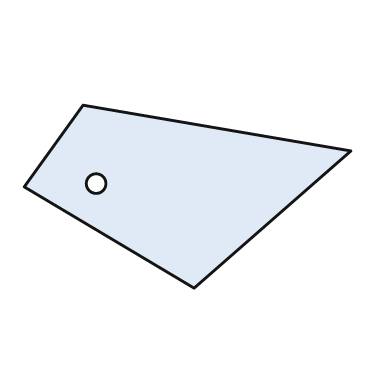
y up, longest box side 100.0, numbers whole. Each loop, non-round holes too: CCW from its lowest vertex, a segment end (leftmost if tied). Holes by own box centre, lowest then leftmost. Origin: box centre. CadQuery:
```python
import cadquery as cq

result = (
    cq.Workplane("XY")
    .moveTo(2.0, -28.0)
    .lineTo(50.0, 14.0)
    .lineTo(-32.0, 28.0)
    .lineTo(-50.0, 3.0)
    .close()
    .moveTo(-28.0, 4.0)
    .circle(3.0)
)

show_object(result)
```